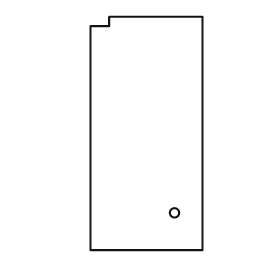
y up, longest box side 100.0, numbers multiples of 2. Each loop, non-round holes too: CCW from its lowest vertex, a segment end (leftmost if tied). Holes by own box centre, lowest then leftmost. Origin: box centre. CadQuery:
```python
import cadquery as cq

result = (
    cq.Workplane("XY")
    .moveTo(-24.0, -50.0)
    .lineTo(24.0, -50.0)
    .lineTo(24.0, 50.0)
    .lineTo(-16.0, 50.0)
    .lineTo(-16.0, 46.0)
    .lineTo(-24.0, 46.0)
    .close()
    .moveTo(12.0, -34.0)
    .circle(2.0)
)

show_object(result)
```